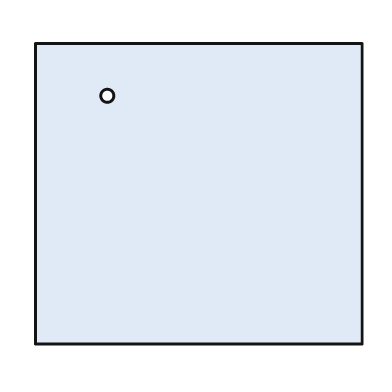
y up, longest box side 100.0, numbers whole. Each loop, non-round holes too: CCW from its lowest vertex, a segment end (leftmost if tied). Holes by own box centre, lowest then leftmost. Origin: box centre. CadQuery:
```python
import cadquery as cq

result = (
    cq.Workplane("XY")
    .moveTo(-50.0, -46.0)
    .lineTo(50.0, -46.0)
    .lineTo(50.0, 46.0)
    .lineTo(-50.0, 46.0)
    .close()
    .moveTo(-28.0, 30.0)
    .circle(2.0)
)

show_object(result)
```